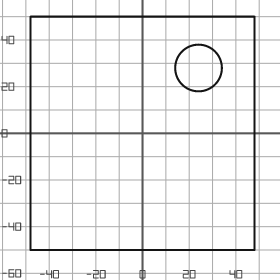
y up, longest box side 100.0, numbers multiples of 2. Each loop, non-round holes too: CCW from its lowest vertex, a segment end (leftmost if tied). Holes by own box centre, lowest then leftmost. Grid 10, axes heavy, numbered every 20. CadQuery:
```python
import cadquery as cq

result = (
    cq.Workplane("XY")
    .moveTo(-48.0, -50.0)
    .lineTo(48.0, -50.0)
    .lineTo(48.0, 50.0)
    .lineTo(-48.0, 50.0)
    .close()
    .moveTo(24.0, 28.0)
    .circle(10.0)
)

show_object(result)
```